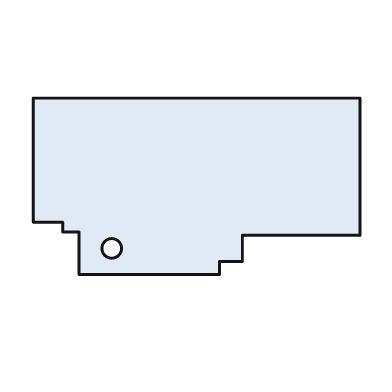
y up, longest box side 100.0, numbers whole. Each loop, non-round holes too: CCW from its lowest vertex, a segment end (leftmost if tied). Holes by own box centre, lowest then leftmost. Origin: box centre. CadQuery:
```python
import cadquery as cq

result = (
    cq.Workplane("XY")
    .moveTo(-36.0, -27.0)
    .lineTo(7.0, -27.0)
    .lineTo(7.0, -23.0)
    .lineTo(14.0, -23.0)
    .lineTo(14.0, -15.0)
    .lineTo(50.0, -15.0)
    .lineTo(50.0, 27.0)
    .lineTo(-50.0, 27.0)
    .lineTo(-50.0, -11.0)
    .lineTo(-41.0, -11.0)
    .lineTo(-41.0, -14.0)
    .lineTo(-36.0, -14.0)
    .close()
    .moveTo(-26.0, -19.0)
    .circle(3.0)
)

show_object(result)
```